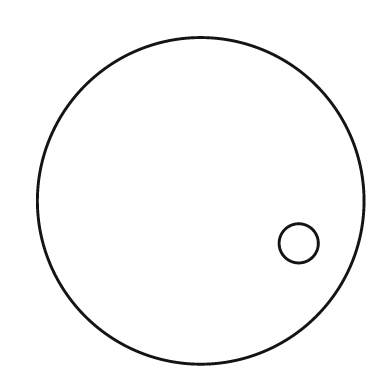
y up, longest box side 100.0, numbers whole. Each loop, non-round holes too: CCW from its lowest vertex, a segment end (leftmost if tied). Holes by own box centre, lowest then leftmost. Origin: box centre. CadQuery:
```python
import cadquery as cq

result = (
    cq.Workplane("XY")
    .moveTo(0.0, 0.0)
    .circle(50.0)
    .moveTo(30.0, -13.0)
    .circle(6.0)
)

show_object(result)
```